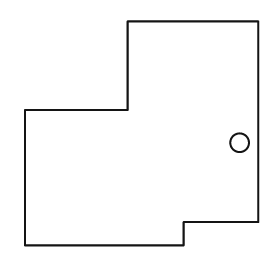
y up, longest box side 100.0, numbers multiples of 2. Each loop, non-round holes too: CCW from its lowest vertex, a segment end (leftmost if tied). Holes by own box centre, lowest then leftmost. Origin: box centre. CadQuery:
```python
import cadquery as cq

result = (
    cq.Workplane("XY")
    .moveTo(-50.0, -48.0)
    .lineTo(18.0, -48.0)
    .lineTo(18.0, -38.0)
    .lineTo(50.0, -38.0)
    .lineTo(50.0, 48.0)
    .lineTo(-6.0, 48.0)
    .lineTo(-6.0, 10.0)
    .lineTo(-50.0, 10.0)
    .close()
    .moveTo(42.0, -4.0)
    .circle(4.0)
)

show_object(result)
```